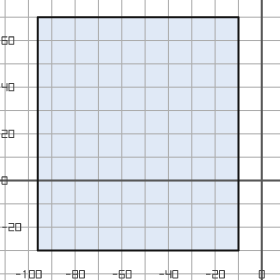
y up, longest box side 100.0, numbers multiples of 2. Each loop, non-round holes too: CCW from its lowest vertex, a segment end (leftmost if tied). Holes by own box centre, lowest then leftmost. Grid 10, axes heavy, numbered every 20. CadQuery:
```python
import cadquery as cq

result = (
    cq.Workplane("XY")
    .moveTo(-96.0, -30.0)
    .lineTo(-10.0, -30.0)
    .lineTo(-10.0, 70.0)
    .lineTo(-96.0, 70.0)
    .close()
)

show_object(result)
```